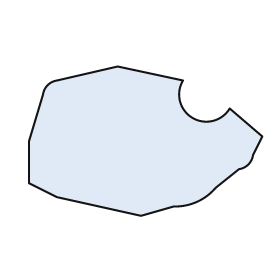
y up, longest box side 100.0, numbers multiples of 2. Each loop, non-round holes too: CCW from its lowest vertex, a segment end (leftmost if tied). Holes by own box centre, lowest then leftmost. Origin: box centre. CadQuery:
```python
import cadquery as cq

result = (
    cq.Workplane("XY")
    .moveTo(-2.0, -32.0)
    .lineTo(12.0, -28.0)
    .threePointArc((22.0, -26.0), (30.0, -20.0))
    .lineTo(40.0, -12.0)
    .threePointArc((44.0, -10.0), (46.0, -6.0))
    .lineTo(50.0, 2.0)
    .lineTo(36.0, 14.0)
    .threePointArc((20.0, 10.0), (16.0, 26.0))
    .lineTo(-12.0, 32.0)
    .lineTo(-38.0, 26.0)
    .threePointArc((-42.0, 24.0), (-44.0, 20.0))
    .lineTo(-50.0, 0.0)
    .lineTo(-50.0, -18.0)
    .lineTo(-38.0, -24.0)
    .close()
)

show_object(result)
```